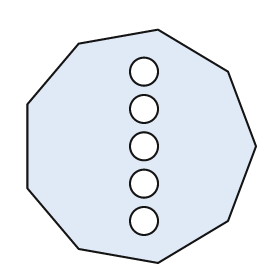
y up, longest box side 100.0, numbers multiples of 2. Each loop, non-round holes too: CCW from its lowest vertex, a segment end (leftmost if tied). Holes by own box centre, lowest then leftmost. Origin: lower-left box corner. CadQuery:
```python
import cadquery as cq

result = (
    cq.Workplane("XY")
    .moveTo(56.0, 0.0)
    .lineTo(86.0, 18.0)
    .lineTo(98.0, 50.0)
    .lineTo(86.0, 82.0)
    .lineTo(56.0, 100.0)
    .lineTo(22.0, 94.0)
    .lineTo(0.0, 68.0)
    .lineTo(0.0, 32.0)
    .lineTo(22.0, 6.0)
    .close()
    .moveTo(50.0, 18.0)
    .circle(6.0)
    .moveTo(50.0, 34.0)
    .circle(6.0)
    .moveTo(50.0, 50.0)
    .circle(6.0)
    .moveTo(50.0, 66.0)
    .circle(6.0)
    .moveTo(50.0, 82.0)
    .circle(6.0)
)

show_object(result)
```